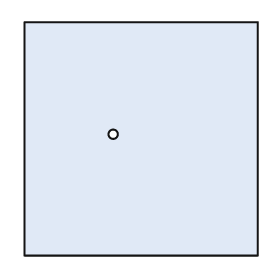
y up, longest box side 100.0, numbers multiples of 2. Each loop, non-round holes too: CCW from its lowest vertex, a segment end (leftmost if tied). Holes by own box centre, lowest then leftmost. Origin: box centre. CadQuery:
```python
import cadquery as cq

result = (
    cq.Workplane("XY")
    .moveTo(-50.0, -50.0)
    .lineTo(50.0, -50.0)
    .lineTo(50.0, 50.0)
    .lineTo(-50.0, 50.0)
    .close()
    .moveTo(-12.0, 2.0)
    .circle(2.0)
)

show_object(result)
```